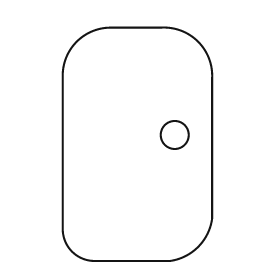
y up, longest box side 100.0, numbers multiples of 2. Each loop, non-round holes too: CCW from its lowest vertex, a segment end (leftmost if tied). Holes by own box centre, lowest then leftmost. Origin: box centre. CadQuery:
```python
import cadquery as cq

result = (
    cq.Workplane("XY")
    .moveTo(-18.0, -50.0)
    .lineTo(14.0, -50.0)
    .threePointArc((26.0, -44.0), (32.0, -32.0))
    .lineTo(32.0, 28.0)
    .threePointArc((26.0, 44.0), (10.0, 50.0))
    .lineTo(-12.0, 50.0)
    .threePointArc((-26.0, 44.0), (-32.0, 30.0))
    .lineTo(-32.0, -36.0)
    .threePointArc((-28.0, -46.0), (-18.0, -50.0))
    .close()
    .moveTo(16.0, 4.0)
    .circle(6.0)
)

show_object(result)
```